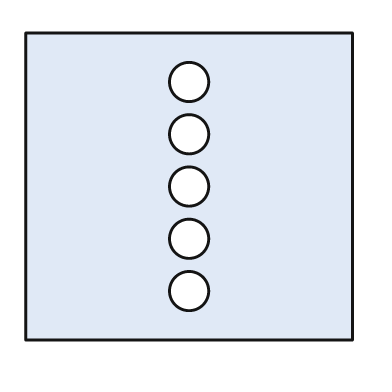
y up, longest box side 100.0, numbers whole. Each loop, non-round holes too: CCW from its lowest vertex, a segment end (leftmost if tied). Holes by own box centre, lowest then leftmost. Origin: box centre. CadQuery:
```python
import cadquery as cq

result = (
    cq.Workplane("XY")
    .moveTo(-50.0, -47.0)
    .lineTo(50.0, -47.0)
    .lineTo(50.0, 47.0)
    .lineTo(-50.0, 47.0)
    .close()
    .moveTo(0.0, -32.0)
    .circle(6.0)
    .moveTo(0.0, -16.0)
    .circle(6.0)
    .moveTo(0.0, 0.0)
    .circle(6.0)
    .moveTo(0.0, 16.0)
    .circle(6.0)
    .moveTo(0.0, 32.0)
    .circle(6.0)
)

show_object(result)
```